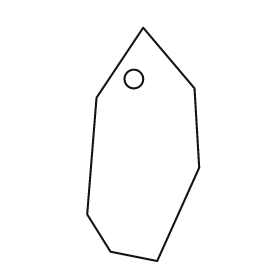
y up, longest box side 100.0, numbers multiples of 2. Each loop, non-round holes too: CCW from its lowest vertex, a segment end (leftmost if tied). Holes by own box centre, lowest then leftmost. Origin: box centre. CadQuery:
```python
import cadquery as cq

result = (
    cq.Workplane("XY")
    .moveTo(6.0, -50.0)
    .lineTo(24.0, -10.0)
    .lineTo(22.0, 24.0)
    .lineTo(0.0, 50.0)
    .lineTo(-20.0, 20.0)
    .lineTo(-24.0, -30.0)
    .lineTo(-14.0, -46.0)
    .close()
    .moveTo(-4.0, 28.0)
    .circle(4.0)
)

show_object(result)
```